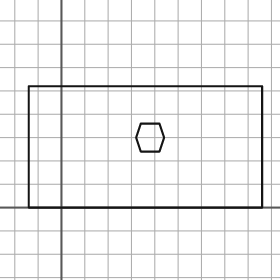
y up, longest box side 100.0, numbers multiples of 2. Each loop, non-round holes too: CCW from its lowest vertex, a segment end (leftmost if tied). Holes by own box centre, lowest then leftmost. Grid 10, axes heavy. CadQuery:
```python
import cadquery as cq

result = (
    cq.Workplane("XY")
    .moveTo(-14.0, 0.0)
    .lineTo(86.0, 0.0)
    .lineTo(86.0, 52.0)
    .lineTo(-14.0, 52.0)
    .close()
    .moveTo(34.0, 24.0)
    .lineTo(42.0, 24.0)
    .lineTo(44.0, 30.0)
    .lineTo(42.0, 36.0)
    .lineTo(34.0, 36.0)
    .lineTo(32.0, 30.0)
    .close()
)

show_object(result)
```